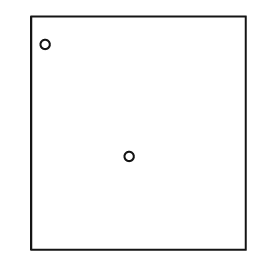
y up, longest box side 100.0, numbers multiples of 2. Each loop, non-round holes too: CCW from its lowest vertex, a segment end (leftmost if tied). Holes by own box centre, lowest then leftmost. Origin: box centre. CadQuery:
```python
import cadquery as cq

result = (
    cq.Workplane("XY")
    .moveTo(-46.0, -50.0)
    .lineTo(46.0, -50.0)
    .lineTo(46.0, 50.0)
    .lineTo(-46.0, 50.0)
    .close()
    .moveTo(-4.0, -10.0)
    .circle(2.0)
    .moveTo(-40.0, 38.0)
    .circle(2.0)
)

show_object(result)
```